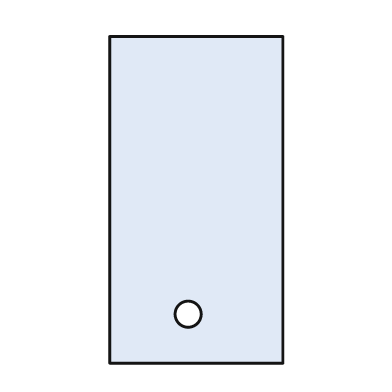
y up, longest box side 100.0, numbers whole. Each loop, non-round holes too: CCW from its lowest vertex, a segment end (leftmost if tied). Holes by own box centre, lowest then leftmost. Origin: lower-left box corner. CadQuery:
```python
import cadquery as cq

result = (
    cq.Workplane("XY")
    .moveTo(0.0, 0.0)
    .lineTo(53.0, 0.0)
    .lineTo(53.0, 100.0)
    .lineTo(0.0, 100.0)
    .close()
    .moveTo(24.0, 15.0)
    .circle(4.0)
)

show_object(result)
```